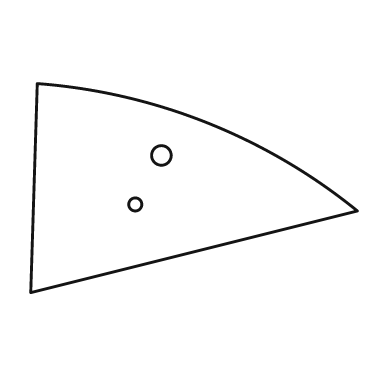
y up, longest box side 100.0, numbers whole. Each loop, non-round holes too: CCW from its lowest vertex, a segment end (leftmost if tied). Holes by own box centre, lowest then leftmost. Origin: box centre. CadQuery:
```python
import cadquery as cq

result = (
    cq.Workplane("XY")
    .moveTo(-50.0, -32.0)
    .lineTo(50.0, -7.0)
    .threePointArc((4.0, 20.0), (-48.0, 32.0))
    .close()
    .moveTo(-18.0, -5.0)
    .circle(2.0)
    .moveTo(-10.0, 10.0)
    .circle(3.0)
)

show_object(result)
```